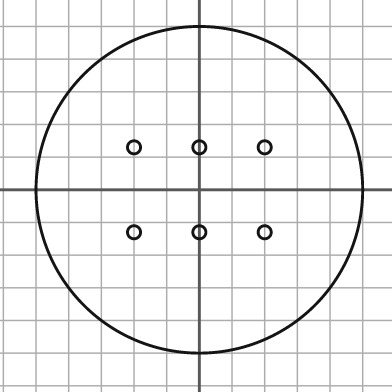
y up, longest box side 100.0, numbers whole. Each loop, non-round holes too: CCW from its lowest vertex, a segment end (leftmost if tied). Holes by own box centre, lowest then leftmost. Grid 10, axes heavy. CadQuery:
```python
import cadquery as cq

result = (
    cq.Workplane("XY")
    .moveTo(0.0, 0.0)
    .circle(50.0)
    .moveTo(-20.0, -13.0)
    .circle(2.0)
    .moveTo(0.0, -13.0)
    .circle(2.0)
    .moveTo(20.0, -13.0)
    .circle(2.0)
    .moveTo(-20.0, 13.0)
    .circle(2.0)
    .moveTo(0.0, 13.0)
    .circle(2.0)
    .moveTo(20.0, 13.0)
    .circle(2.0)
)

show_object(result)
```